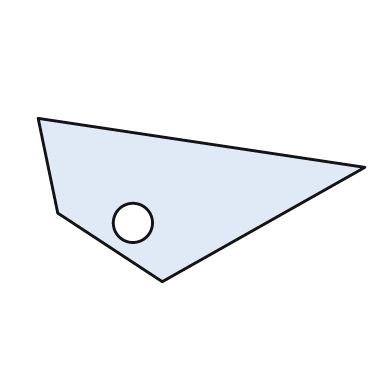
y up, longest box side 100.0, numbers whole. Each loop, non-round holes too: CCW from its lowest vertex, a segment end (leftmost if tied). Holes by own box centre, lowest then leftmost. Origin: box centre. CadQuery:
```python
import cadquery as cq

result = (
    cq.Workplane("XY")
    .moveTo(-12.0, -25.0)
    .lineTo(50.0, 10.0)
    .lineTo(-50.0, 25.0)
    .lineTo(-44.0, -4.0)
    .close()
    .moveTo(-21.0, -7.0)
    .circle(6.0)
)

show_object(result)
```